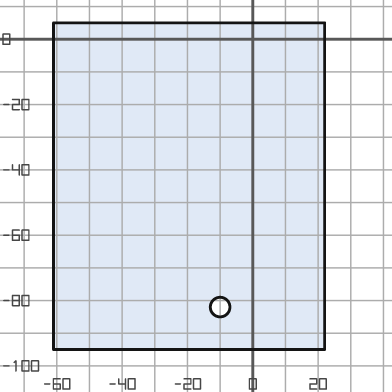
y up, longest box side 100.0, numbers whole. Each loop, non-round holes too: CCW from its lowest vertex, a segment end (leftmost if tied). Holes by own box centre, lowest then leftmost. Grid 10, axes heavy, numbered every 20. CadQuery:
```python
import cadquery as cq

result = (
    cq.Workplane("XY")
    .moveTo(-61.0, -95.0)
    .lineTo(22.0, -95.0)
    .lineTo(22.0, 5.0)
    .lineTo(-61.0, 5.0)
    .close()
    .moveTo(-10.0, -82.0)
    .circle(3.0)
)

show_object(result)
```